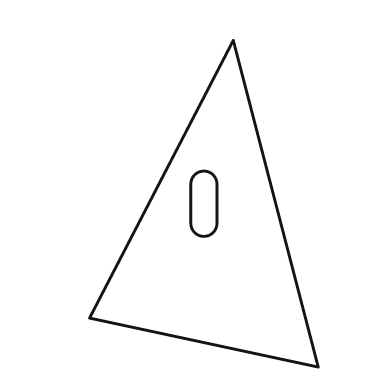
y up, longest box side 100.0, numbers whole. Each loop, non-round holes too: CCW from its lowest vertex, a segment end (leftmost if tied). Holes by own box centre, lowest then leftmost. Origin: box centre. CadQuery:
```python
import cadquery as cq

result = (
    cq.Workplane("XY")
    .moveTo(35.0, -50.0)
    .lineTo(9.0, 50.0)
    .lineTo(-35.0, -35.0)
    .close()
    .moveTo(-4.0, -6.0)
    .threePointArc((0.0, -10.0), (4.0, -6.0))
    .lineTo(4.0, 6.0)
    .threePointArc((0.0, 10.0), (-4.0, 6.0))
    .close()
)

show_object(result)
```